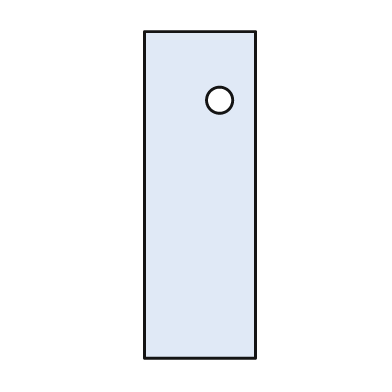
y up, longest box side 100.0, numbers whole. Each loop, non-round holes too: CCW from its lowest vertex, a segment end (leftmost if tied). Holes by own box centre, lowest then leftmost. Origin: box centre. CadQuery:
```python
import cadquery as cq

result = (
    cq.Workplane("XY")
    .moveTo(-17.0, -50.0)
    .lineTo(17.0, -50.0)
    .lineTo(17.0, 50.0)
    .lineTo(-17.0, 50.0)
    .close()
    .moveTo(6.0, 29.0)
    .circle(4.0)
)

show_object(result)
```